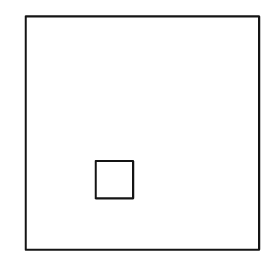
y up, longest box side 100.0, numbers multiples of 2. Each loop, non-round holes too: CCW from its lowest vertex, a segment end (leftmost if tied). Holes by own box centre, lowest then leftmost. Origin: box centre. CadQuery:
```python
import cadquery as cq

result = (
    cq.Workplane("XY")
    .moveTo(-50.0, -50.0)
    .lineTo(50.0, -50.0)
    .lineTo(50.0, 50.0)
    .lineTo(-50.0, 50.0)
    .close()
    .moveTo(-20.0, -28.0)
    .lineTo(-4.0, -28.0)
    .lineTo(-4.0, -12.0)
    .lineTo(-20.0, -12.0)
    .close()
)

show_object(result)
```